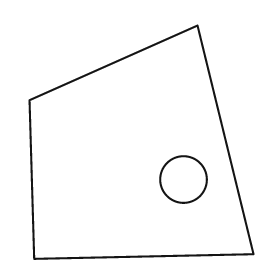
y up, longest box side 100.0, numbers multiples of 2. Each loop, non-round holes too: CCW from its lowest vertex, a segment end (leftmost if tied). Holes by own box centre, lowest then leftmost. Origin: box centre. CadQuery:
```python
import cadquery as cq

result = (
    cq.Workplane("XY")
    .moveTo(-46.0, -50.0)
    .lineTo(48.0, -48.0)
    .lineTo(24.0, 50.0)
    .lineTo(-48.0, 18.0)
    .close()
    .moveTo(18.0, -16.0)
    .circle(10.0)
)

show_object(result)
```